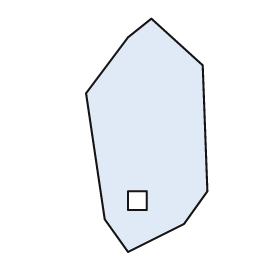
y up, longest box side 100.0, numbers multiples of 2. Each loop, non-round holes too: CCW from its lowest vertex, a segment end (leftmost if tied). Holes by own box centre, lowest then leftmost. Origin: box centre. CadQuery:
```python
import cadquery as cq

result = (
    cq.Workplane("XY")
    .moveTo(-8.0, -50.0)
    .lineTo(16.0, -38.0)
    .lineTo(26.0, -24.0)
    .lineTo(24.0, 30.0)
    .lineTo(2.0, 50.0)
    .lineTo(-8.0, 42.0)
    .lineTo(-26.0, 18.0)
    .lineTo(-18.0, -36.0)
    .close()
    .moveTo(-8.0, -32.0)
    .lineTo(0.0, -32.0)
    .lineTo(0.0, -24.0)
    .lineTo(-8.0, -24.0)
    .close()
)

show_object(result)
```